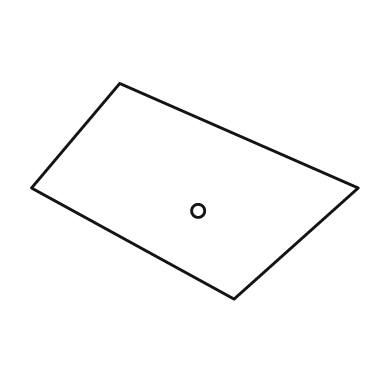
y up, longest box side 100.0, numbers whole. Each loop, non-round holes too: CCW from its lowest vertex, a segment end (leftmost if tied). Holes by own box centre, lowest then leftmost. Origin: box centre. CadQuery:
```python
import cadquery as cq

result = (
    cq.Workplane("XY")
    .moveTo(12.0, -33.0)
    .lineTo(50.0, 1.0)
    .lineTo(-23.0, 33.0)
    .lineTo(-50.0, 1.0)
    .close()
    .moveTo(1.0, -6.0)
    .circle(2.0)
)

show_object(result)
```